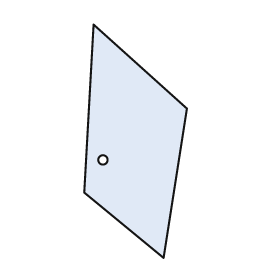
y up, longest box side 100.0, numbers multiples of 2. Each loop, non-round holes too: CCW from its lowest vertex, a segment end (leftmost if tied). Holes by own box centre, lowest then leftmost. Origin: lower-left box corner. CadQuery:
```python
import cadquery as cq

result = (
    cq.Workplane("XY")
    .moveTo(34.0, 0.0)
    .lineTo(44.0, 64.0)
    .lineTo(4.0, 100.0)
    .lineTo(0.0, 28.0)
    .close()
    .moveTo(8.0, 42.0)
    .circle(2.0)
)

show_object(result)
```